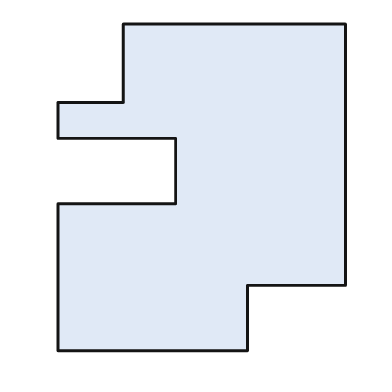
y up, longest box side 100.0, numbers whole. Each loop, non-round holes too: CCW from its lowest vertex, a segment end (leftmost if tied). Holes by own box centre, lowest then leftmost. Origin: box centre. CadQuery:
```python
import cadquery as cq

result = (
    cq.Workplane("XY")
    .moveTo(-44.0, -50.0)
    .lineTo(14.0, -50.0)
    .lineTo(14.0, -30.0)
    .lineTo(44.0, -30.0)
    .lineTo(44.0, 50.0)
    .lineTo(-24.0, 50.0)
    .lineTo(-24.0, 26.0)
    .lineTo(-44.0, 26.0)
    .lineTo(-44.0, 15.0)
    .lineTo(-8.0, 15.0)
    .lineTo(-8.0, -5.0)
    .lineTo(-44.0, -5.0)
    .close()
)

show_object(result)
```